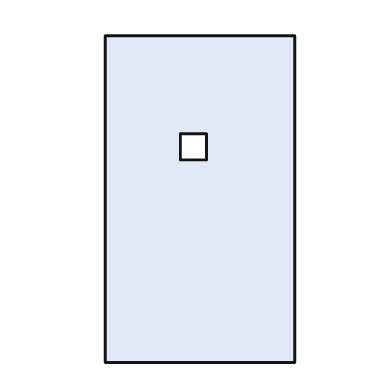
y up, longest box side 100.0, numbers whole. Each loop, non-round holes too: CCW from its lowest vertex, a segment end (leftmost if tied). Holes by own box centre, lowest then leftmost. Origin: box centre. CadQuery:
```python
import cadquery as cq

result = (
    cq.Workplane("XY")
    .moveTo(-29.0, -50.0)
    .lineTo(29.0, -50.0)
    .lineTo(29.0, 50.0)
    .lineTo(-29.0, 50.0)
    .close()
    .moveTo(-6.0, 12.0)
    .lineTo(2.0, 12.0)
    .lineTo(2.0, 20.0)
    .lineTo(-6.0, 20.0)
    .close()
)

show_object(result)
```